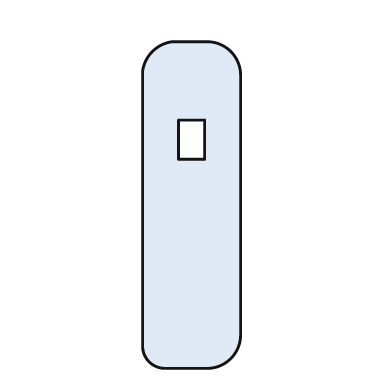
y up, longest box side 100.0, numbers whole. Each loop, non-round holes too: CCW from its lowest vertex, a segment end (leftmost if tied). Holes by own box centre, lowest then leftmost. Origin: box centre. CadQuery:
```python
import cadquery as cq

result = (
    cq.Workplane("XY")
    .moveTo(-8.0, -50.0)
    .lineTo(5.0, -50.0)
    .threePointArc((12.0, -47.0), (15.0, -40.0))
    .lineTo(15.0, 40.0)
    .threePointArc((12.0, 47.0), (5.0, 50.0))
    .lineTo(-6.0, 50.0)
    .threePointArc((-12.0, 47.0), (-15.0, 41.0))
    .lineTo(-15.0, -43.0)
    .threePointArc((-13.0, -48.0), (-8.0, -50.0))
    .close()
    .moveTo(-4.0, 14.0)
    .lineTo(4.0, 14.0)
    .lineTo(4.0, 26.0)
    .lineTo(-4.0, 26.0)
    .close()
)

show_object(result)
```